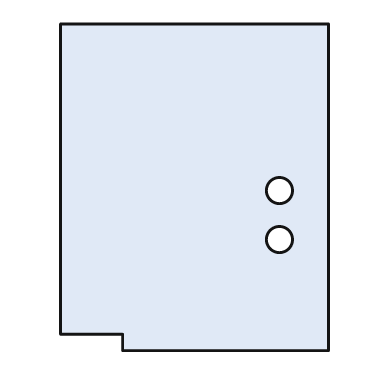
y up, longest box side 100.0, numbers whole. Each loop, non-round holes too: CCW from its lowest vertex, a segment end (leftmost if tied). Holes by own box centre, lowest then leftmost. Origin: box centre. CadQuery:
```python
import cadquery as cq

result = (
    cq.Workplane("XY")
    .moveTo(-22.0, -50.0)
    .lineTo(41.0, -50.0)
    .lineTo(41.0, 50.0)
    .lineTo(-41.0, 50.0)
    .lineTo(-41.0, -45.0)
    .lineTo(-22.0, -45.0)
    .close()
    .moveTo(26.0, -16.0)
    .circle(4.0)
    .moveTo(26.0, -1.0)
    .circle(4.0)
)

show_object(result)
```